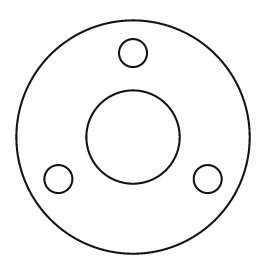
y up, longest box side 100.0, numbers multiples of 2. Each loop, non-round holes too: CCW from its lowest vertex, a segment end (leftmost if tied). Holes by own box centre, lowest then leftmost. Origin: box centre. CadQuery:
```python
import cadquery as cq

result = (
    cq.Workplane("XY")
    .moveTo(0.0, 0.0)
    .circle(50.0)
    .moveTo(-32.0, -18.0)
    .circle(6.0)
    .moveTo(32.0, -18.0)
    .circle(6.0)
    .moveTo(0.0, 0.0)
    .circle(20.0)
    .moveTo(0.0, 36.0)
    .circle(6.0)
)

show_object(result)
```